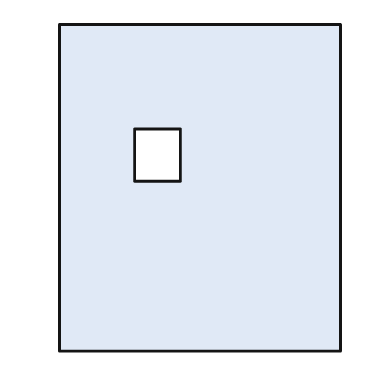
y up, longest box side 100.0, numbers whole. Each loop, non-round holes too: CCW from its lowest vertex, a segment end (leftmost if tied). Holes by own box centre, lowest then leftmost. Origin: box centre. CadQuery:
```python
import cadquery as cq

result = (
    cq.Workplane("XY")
    .moveTo(-43.0, -50.0)
    .lineTo(43.0, -50.0)
    .lineTo(43.0, 50.0)
    .lineTo(-43.0, 50.0)
    .close()
    .moveTo(-20.0, 2.0)
    .lineTo(-6.0, 2.0)
    .lineTo(-6.0, 18.0)
    .lineTo(-20.0, 18.0)
    .close()
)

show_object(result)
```